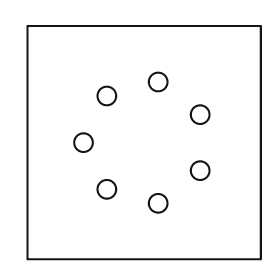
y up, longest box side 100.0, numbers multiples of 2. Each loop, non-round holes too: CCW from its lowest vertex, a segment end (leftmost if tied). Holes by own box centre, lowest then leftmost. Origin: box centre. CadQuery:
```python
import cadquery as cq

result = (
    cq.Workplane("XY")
    .moveTo(-50.0, -50.0)
    .lineTo(50.0, -50.0)
    .lineTo(50.0, 50.0)
    .lineTo(-50.0, 50.0)
    .close()
    .moveTo(6.0, -26.0)
    .circle(4.0)
    .moveTo(-16.0, -20.0)
    .circle(4.0)
    .moveTo(24.0, -12.0)
    .circle(4.0)
    .moveTo(-26.0, 0.0)
    .circle(4.0)
    .moveTo(24.0, 12.0)
    .circle(4.0)
    .moveTo(-16.0, 20.0)
    .circle(4.0)
    .moveTo(6.0, 26.0)
    .circle(4.0)
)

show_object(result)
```